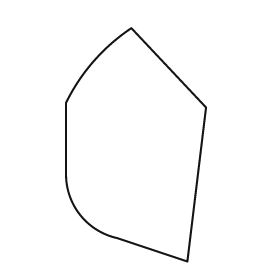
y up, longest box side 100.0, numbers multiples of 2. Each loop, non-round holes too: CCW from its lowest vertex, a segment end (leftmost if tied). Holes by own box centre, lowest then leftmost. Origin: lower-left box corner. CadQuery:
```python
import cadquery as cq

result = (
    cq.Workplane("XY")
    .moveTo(52.0, 0.0)
    .lineTo(60.0, 66.0)
    .lineTo(28.0, 100.0)
    .threePointArc((12.0, 86.0), (0.0, 68.0))
    .lineTo(0.0, 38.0)
    .threePointArc((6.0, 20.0), (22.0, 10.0))
    .close()
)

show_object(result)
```